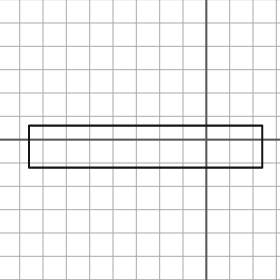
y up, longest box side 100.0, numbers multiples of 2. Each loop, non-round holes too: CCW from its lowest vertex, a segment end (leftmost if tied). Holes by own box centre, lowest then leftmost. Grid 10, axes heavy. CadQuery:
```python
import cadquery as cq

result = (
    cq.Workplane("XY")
    .moveTo(-76.0, -12.0)
    .lineTo(24.0, -12.0)
    .lineTo(24.0, 6.0)
    .lineTo(-76.0, 6.0)
    .close()
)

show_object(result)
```